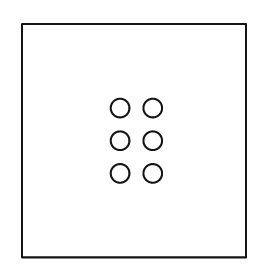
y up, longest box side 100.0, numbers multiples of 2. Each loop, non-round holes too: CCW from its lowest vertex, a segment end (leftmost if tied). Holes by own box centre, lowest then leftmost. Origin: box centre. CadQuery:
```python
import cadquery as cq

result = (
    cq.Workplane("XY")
    .moveTo(-48.0, -50.0)
    .lineTo(48.0, -50.0)
    .lineTo(48.0, 50.0)
    .lineTo(-48.0, 50.0)
    .close()
    .moveTo(-6.0, -14.0)
    .circle(4.0)
    .moveTo(8.0, -14.0)
    .circle(4.0)
    .moveTo(-6.0, 0.0)
    .circle(4.0)
    .moveTo(8.0, 0.0)
    .circle(4.0)
    .moveTo(-6.0, 14.0)
    .circle(4.0)
    .moveTo(8.0, 14.0)
    .circle(4.0)
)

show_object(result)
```